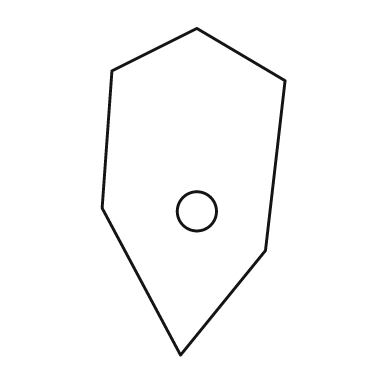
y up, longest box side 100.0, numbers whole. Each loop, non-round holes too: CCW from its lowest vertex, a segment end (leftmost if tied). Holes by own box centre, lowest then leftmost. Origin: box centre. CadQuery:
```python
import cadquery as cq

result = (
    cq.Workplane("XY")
    .moveTo(-4.0, -50.0)
    .lineTo(22.0, -18.0)
    .lineTo(28.0, 34.0)
    .lineTo(1.0, 50.0)
    .lineTo(-25.0, 37.0)
    .lineTo(-28.0, -5.0)
    .close()
    .moveTo(1.0, -6.0)
    .circle(6.0)
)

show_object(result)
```